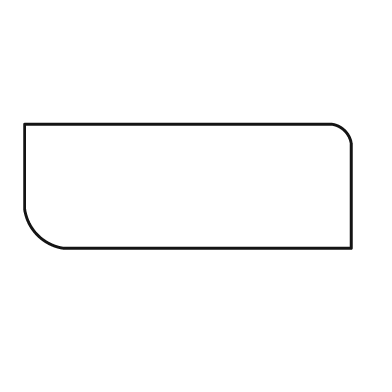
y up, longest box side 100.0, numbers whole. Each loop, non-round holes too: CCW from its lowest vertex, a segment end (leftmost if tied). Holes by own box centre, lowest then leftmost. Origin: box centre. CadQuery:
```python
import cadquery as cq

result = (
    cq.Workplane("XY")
    .moveTo(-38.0, -19.0)
    .lineTo(50.0, -19.0)
    .lineTo(50.0, 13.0)
    .threePointArc((48.0, 17.0), (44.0, 19.0))
    .lineTo(-50.0, 19.0)
    .lineTo(-50.0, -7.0)
    .threePointArc((-46.0, -15.0), (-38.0, -19.0))
    .close()
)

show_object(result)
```